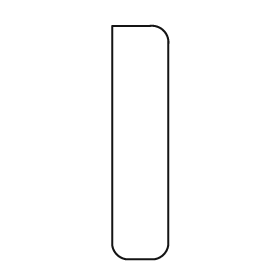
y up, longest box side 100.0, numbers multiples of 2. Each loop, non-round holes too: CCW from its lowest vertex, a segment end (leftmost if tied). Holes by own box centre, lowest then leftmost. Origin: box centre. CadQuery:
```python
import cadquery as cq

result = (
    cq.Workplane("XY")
    .moveTo(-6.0, -50.0)
    .lineTo(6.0, -50.0)
    .threePointArc((10.0, -48.0), (12.0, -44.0))
    .lineTo(12.0, 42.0)
    .threePointArc((10.0, 48.0), (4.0, 50.0))
    .lineTo(-12.0, 50.0)
    .lineTo(-12.0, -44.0)
    .threePointArc((-10.0, -48.0), (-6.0, -50.0))
    .close()
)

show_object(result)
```